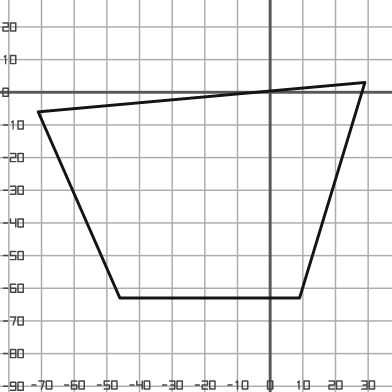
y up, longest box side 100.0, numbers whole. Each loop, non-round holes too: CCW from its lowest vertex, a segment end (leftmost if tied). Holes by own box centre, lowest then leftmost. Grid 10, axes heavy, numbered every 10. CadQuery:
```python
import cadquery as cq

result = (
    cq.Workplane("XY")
    .moveTo(-46.0, -63.0)
    .lineTo(9.0, -63.0)
    .lineTo(29.0, 3.0)
    .lineTo(-71.0, -6.0)
    .close()
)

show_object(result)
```